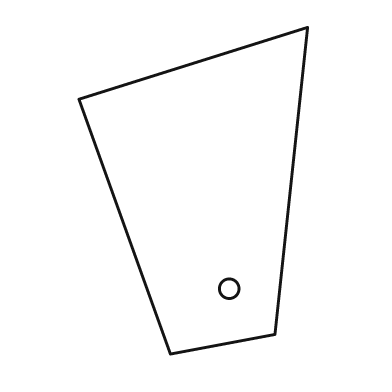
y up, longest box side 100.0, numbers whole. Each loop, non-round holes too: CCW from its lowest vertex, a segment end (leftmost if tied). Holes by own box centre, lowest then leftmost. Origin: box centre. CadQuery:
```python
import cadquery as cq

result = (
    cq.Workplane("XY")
    .moveTo(-7.0, -50.0)
    .lineTo(25.0, -44.0)
    .lineTo(35.0, 50.0)
    .lineTo(-35.0, 28.0)
    .close()
    .moveTo(11.0, -30.0)
    .circle(3.0)
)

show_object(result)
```